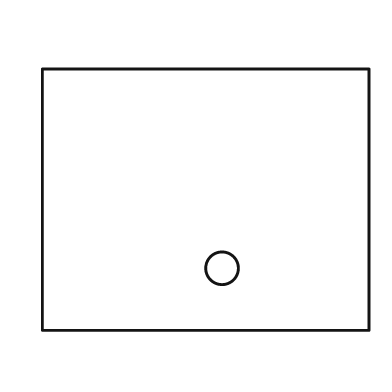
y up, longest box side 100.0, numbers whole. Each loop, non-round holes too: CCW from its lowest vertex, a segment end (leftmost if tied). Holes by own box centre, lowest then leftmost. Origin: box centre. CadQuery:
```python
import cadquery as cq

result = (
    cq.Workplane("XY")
    .moveTo(-50.0, -40.0)
    .lineTo(50.0, -40.0)
    .lineTo(50.0, 40.0)
    .lineTo(-50.0, 40.0)
    .close()
    .moveTo(5.0, -21.0)
    .circle(5.0)
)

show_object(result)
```